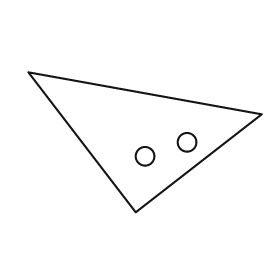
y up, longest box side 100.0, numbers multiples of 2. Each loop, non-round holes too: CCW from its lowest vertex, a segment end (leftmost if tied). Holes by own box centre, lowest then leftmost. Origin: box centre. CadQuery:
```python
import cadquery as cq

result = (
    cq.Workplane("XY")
    .moveTo(-4.0, -30.0)
    .lineTo(50.0, 12.0)
    .lineTo(-50.0, 30.0)
    .close()
    .moveTo(0.0, -6.0)
    .circle(4.0)
    .moveTo(18.0, 0.0)
    .circle(4.0)
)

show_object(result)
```